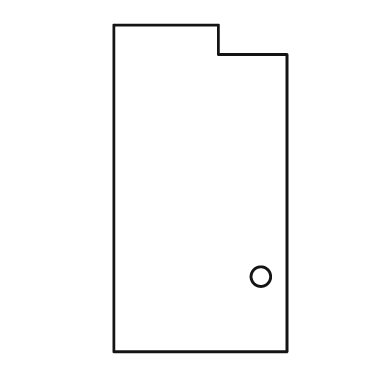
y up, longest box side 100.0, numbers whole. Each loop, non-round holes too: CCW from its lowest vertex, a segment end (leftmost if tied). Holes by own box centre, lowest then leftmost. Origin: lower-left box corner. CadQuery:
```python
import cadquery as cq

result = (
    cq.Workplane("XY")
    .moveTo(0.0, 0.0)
    .lineTo(53.0, 0.0)
    .lineTo(53.0, 91.0)
    .lineTo(32.0, 91.0)
    .lineTo(32.0, 100.0)
    .lineTo(0.0, 100.0)
    .close()
    .moveTo(45.0, 23.0)
    .circle(3.0)
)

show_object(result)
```